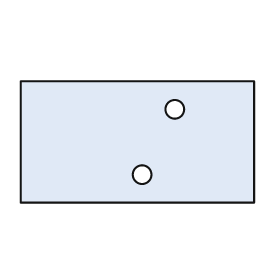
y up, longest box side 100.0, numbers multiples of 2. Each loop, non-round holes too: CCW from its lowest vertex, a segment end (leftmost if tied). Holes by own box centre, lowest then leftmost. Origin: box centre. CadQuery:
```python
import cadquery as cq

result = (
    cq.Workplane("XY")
    .moveTo(-50.0, -26.0)
    .lineTo(50.0, -26.0)
    .lineTo(50.0, 26.0)
    .lineTo(-50.0, 26.0)
    .close()
    .moveTo(2.0, -14.0)
    .circle(4.0)
    .moveTo(16.0, 14.0)
    .circle(4.0)
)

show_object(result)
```